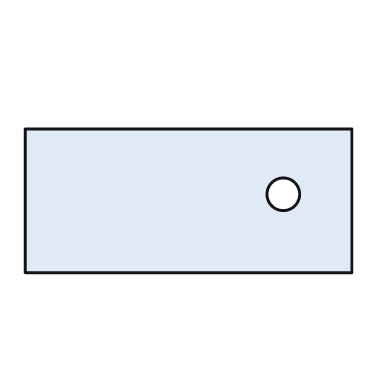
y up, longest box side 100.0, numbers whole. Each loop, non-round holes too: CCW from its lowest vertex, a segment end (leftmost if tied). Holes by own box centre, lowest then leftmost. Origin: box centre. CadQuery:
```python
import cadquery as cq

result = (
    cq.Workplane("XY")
    .moveTo(-50.0, -22.0)
    .lineTo(50.0, -22.0)
    .lineTo(50.0, 22.0)
    .lineTo(-50.0, 22.0)
    .close()
    .moveTo(29.0, 2.0)
    .circle(5.0)
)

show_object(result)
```